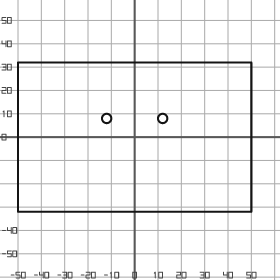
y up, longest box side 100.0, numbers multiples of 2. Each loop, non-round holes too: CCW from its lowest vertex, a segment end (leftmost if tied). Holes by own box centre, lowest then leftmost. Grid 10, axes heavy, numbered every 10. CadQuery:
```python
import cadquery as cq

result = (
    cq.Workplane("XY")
    .moveTo(-50.0, -32.0)
    .lineTo(50.0, -32.0)
    .lineTo(50.0, 32.0)
    .lineTo(-50.0, 32.0)
    .close()
    .moveTo(-12.0, 8.0)
    .circle(2.0)
    .moveTo(12.0, 8.0)
    .circle(2.0)
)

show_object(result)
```